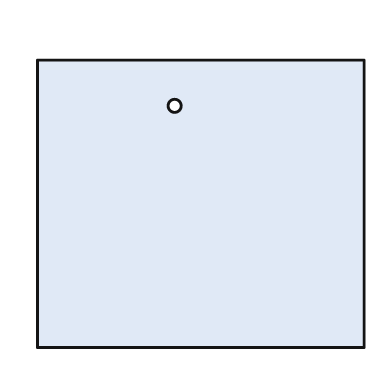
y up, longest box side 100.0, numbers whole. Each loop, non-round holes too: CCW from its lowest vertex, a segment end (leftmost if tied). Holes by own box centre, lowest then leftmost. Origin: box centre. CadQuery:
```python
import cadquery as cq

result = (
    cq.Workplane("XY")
    .moveTo(-50.0, -44.0)
    .lineTo(50.0, -44.0)
    .lineTo(50.0, 44.0)
    .lineTo(-50.0, 44.0)
    .close()
    .moveTo(-8.0, 30.0)
    .circle(2.0)
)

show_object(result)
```